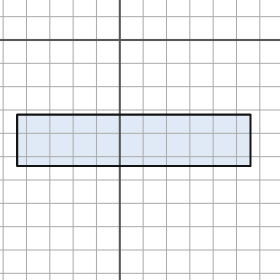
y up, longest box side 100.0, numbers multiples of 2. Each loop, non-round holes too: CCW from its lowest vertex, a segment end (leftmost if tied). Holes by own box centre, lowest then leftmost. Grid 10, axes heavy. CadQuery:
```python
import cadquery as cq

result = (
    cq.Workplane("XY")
    .moveTo(-44.0, -54.0)
    .lineTo(56.0, -54.0)
    .lineTo(56.0, -32.0)
    .lineTo(-44.0, -32.0)
    .close()
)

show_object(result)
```